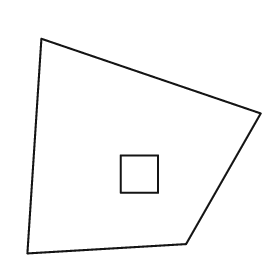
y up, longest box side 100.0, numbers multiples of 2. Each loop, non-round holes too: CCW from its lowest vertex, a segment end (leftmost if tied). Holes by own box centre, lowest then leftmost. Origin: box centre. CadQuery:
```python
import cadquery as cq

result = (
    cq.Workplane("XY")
    .moveTo(-50.0, -46.0)
    .lineTo(18.0, -42.0)
    .lineTo(50.0, 14.0)
    .lineTo(-44.0, 46.0)
    .close()
    .moveTo(-10.0, -20.0)
    .lineTo(6.0, -20.0)
    .lineTo(6.0, -4.0)
    .lineTo(-10.0, -4.0)
    .close()
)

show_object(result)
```